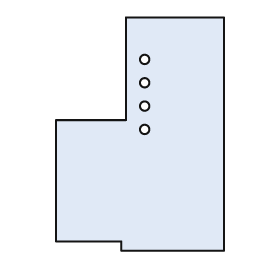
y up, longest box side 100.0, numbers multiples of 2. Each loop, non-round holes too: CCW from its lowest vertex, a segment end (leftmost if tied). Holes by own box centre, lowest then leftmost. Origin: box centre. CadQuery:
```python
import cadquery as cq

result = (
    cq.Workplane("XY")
    .moveTo(-8.0, -50.0)
    .lineTo(36.0, -50.0)
    .lineTo(36.0, 50.0)
    .lineTo(-6.0, 50.0)
    .lineTo(-6.0, 6.0)
    .lineTo(-36.0, 6.0)
    .lineTo(-36.0, -46.0)
    .lineTo(-8.0, -46.0)
    .close()
    .moveTo(2.0, 2.0)
    .circle(2.0)
    .moveTo(2.0, 12.0)
    .circle(2.0)
    .moveTo(2.0, 22.0)
    .circle(2.0)
    .moveTo(2.0, 32.0)
    .circle(2.0)
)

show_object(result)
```